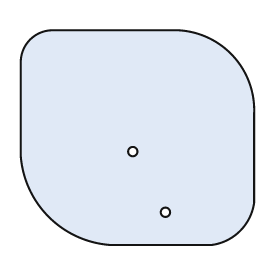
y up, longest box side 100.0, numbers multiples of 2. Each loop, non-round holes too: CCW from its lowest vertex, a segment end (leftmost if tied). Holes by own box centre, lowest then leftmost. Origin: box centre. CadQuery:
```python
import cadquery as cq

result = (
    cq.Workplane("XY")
    .moveTo(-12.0, -46.0)
    .lineTo(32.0, -46.0)
    .threePointArc((44.0, -40.0), (50.0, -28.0))
    .lineTo(50.0, 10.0)
    .threePointArc((40.0, 36.0), (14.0, 46.0))
    .lineTo(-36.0, 46.0)
    .threePointArc((-46.0, 42.0), (-50.0, 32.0))
    .lineTo(-50.0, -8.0)
    .threePointArc((-38.0, -34.0), (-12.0, -46.0))
    .close()
    .moveTo(12.0, -32.0)
    .circle(2.0)
    .moveTo(-2.0, -6.0)
    .circle(2.0)
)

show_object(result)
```